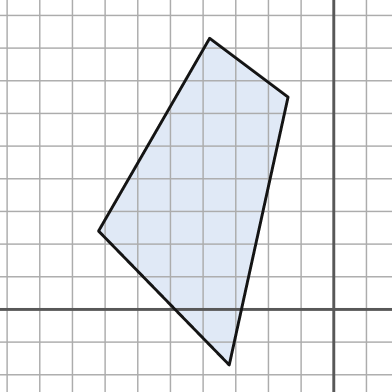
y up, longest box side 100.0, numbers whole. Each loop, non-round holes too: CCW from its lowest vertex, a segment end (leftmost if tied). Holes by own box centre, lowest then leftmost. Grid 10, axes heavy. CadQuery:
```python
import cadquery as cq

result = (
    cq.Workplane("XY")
    .moveTo(-32.0, -17.0)
    .lineTo(-14.0, 65.0)
    .lineTo(-38.0, 83.0)
    .lineTo(-72.0, 24.0)
    .close()
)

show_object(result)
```